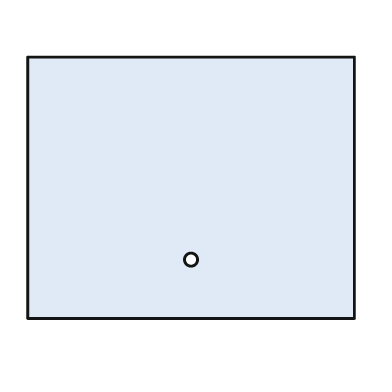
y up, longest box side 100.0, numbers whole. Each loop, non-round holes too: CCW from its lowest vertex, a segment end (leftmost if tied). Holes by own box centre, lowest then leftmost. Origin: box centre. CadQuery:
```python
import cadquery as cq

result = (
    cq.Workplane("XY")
    .moveTo(-50.0, -40.0)
    .lineTo(50.0, -40.0)
    .lineTo(50.0, 40.0)
    .lineTo(-50.0, 40.0)
    .close()
    .moveTo(0.0, -22.0)
    .circle(2.0)
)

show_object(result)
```